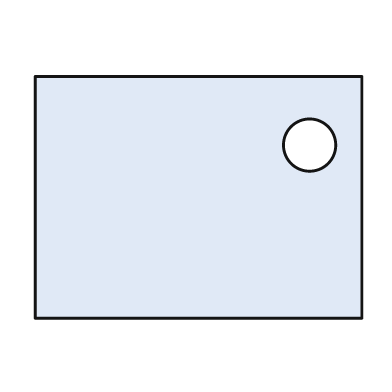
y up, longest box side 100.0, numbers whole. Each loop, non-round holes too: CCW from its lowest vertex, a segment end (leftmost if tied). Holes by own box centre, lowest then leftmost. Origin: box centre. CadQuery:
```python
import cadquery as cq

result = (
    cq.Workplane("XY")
    .moveTo(-50.0, -37.0)
    .lineTo(50.0, -37.0)
    .lineTo(50.0, 37.0)
    .lineTo(-50.0, 37.0)
    .close()
    .moveTo(34.0, 16.0)
    .circle(8.0)
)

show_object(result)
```